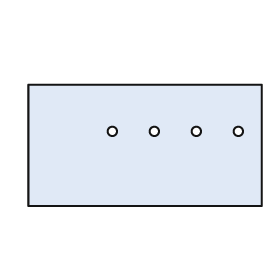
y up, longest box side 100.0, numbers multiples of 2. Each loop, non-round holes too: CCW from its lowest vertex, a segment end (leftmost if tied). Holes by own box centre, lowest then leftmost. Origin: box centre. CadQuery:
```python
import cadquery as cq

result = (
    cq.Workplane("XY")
    .moveTo(-50.0, -26.0)
    .lineTo(50.0, -26.0)
    .lineTo(50.0, 26.0)
    .lineTo(-50.0, 26.0)
    .close()
    .moveTo(-14.0, 6.0)
    .circle(2.0)
    .moveTo(4.0, 6.0)
    .circle(2.0)
    .moveTo(22.0, 6.0)
    .circle(2.0)
    .moveTo(40.0, 6.0)
    .circle(2.0)
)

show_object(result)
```